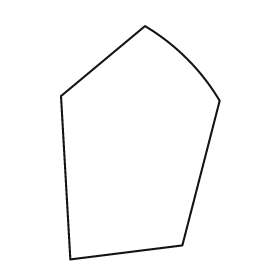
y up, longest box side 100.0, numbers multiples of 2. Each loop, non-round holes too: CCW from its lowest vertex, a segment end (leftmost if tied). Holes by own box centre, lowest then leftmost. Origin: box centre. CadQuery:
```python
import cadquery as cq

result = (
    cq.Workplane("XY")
    .moveTo(-30.0, -50.0)
    .lineTo(18.0, -44.0)
    .lineTo(34.0, 18.0)
    .threePointArc((20.0, 36.0), (2.0, 50.0))
    .lineTo(-34.0, 20.0)
    .close()
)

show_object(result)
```